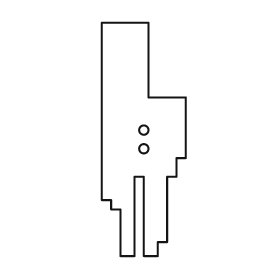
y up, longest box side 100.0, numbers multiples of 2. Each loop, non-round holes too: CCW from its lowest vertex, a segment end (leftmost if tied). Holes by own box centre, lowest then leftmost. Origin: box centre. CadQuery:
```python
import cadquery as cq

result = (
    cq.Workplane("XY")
    .moveTo(-10.0, -50.0)
    .lineTo(-4.0, -50.0)
    .lineTo(-4.0, -16.0)
    .lineTo(0.0, -16.0)
    .lineTo(0.0, -50.0)
    .lineTo(6.0, -50.0)
    .lineTo(6.0, -44.0)
    .lineTo(10.0, -44.0)
    .lineTo(10.0, -16.0)
    .lineTo(14.0, -16.0)
    .lineTo(14.0, -8.0)
    .lineTo(18.0, -8.0)
    .lineTo(18.0, 18.0)
    .lineTo(2.0, 18.0)
    .lineTo(2.0, 50.0)
    .lineTo(-18.0, 50.0)
    .lineTo(-18.0, -26.0)
    .lineTo(-14.0, -26.0)
    .lineTo(-14.0, -30.0)
    .lineTo(-10.0, -30.0)
    .close()
    .moveTo(0.0, -4.0)
    .circle(2.0)
    .moveTo(0.0, 4.0)
    .circle(2.0)
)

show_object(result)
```